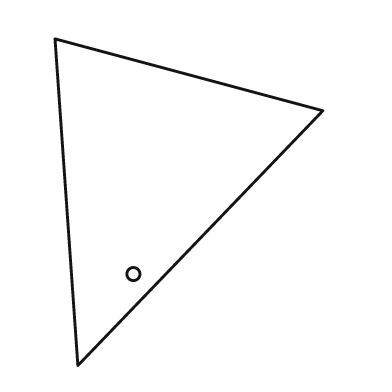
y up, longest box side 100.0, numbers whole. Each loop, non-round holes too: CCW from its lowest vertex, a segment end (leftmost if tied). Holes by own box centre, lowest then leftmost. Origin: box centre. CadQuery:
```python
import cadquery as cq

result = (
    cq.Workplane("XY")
    .moveTo(-34.0, -50.0)
    .lineTo(41.0, 28.0)
    .lineTo(-41.0, 50.0)
    .close()
    .moveTo(-17.0, -22.0)
    .circle(2.0)
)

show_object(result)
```